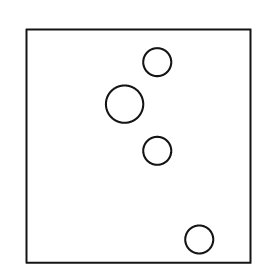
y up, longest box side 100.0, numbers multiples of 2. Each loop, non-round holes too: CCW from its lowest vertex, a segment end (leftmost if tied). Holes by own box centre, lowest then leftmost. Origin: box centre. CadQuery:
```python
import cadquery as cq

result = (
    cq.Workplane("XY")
    .moveTo(-48.0, -50.0)
    .lineTo(48.0, -50.0)
    .lineTo(48.0, 50.0)
    .lineTo(-48.0, 50.0)
    .close()
    .moveTo(26.0, -40.0)
    .circle(6.0)
    .moveTo(8.0, -2.0)
    .circle(6.0)
    .moveTo(-6.0, 18.0)
    .circle(8.0)
    .moveTo(8.0, 36.0)
    .circle(6.0)
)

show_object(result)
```